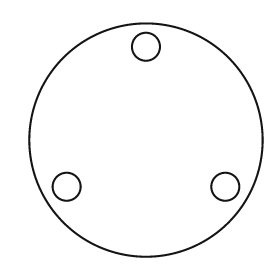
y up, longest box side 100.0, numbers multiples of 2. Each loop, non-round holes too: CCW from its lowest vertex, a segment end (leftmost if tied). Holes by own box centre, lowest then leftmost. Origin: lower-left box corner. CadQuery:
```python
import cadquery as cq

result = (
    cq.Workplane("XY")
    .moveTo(50.0, 50.0)
    .circle(50.0)
    .moveTo(16.0, 30.0)
    .circle(6.0)
    .moveTo(84.0, 30.0)
    .circle(6.0)
    .moveTo(50.0, 90.0)
    .circle(6.0)
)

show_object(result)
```